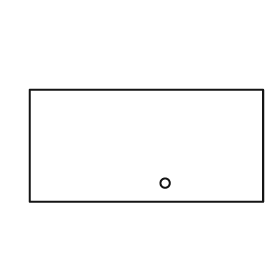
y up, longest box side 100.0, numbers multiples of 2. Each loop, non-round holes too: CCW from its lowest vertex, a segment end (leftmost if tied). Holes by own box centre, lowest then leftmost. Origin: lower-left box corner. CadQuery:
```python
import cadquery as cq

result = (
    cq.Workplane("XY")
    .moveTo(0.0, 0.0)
    .lineTo(100.0, 0.0)
    .lineTo(100.0, 48.0)
    .lineTo(0.0, 48.0)
    .close()
    .moveTo(58.0, 8.0)
    .circle(2.0)
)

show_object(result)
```